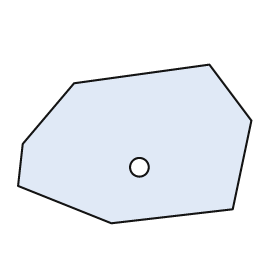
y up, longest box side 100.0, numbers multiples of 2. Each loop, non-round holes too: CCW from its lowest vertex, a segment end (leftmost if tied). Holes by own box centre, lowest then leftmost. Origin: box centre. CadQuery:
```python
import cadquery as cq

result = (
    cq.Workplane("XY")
    .moveTo(-10.0, -34.0)
    .lineTo(42.0, -28.0)
    .lineTo(50.0, 10.0)
    .lineTo(32.0, 34.0)
    .lineTo(-26.0, 26.0)
    .lineTo(-48.0, 0.0)
    .lineTo(-50.0, -18.0)
    .close()
    .moveTo(2.0, -10.0)
    .circle(4.0)
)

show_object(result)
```